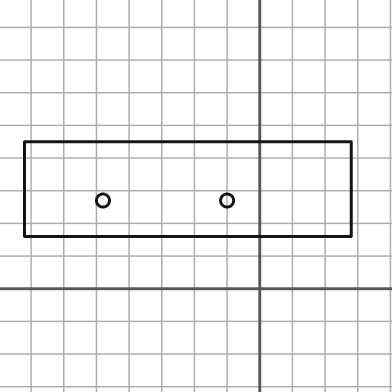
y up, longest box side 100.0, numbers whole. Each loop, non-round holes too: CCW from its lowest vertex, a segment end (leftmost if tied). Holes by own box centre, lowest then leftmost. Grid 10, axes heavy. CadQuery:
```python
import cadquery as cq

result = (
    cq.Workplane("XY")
    .moveTo(-72.0, 16.0)
    .lineTo(28.0, 16.0)
    .lineTo(28.0, 45.0)
    .lineTo(-72.0, 45.0)
    .close()
    .moveTo(-48.0, 27.0)
    .circle(2.0)
    .moveTo(-10.0, 27.0)
    .circle(2.0)
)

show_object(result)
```